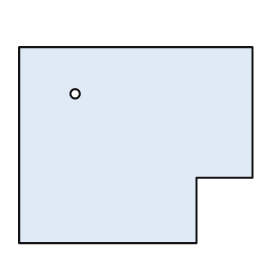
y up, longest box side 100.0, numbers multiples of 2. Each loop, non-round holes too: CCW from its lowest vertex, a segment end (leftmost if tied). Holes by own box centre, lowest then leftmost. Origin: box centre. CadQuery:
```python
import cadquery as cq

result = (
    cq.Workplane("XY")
    .moveTo(-50.0, -42.0)
    .lineTo(26.0, -42.0)
    .lineTo(26.0, -14.0)
    .lineTo(50.0, -14.0)
    .lineTo(50.0, 42.0)
    .lineTo(-50.0, 42.0)
    .close()
    .moveTo(-26.0, 22.0)
    .circle(2.0)
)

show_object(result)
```